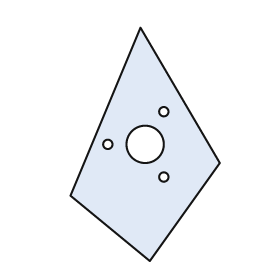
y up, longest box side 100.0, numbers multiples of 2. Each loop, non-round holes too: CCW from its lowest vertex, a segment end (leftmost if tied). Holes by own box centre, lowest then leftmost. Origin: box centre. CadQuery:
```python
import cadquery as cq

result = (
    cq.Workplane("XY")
    .moveTo(2.0, -50.0)
    .lineTo(32.0, -8.0)
    .lineTo(-2.0, 50.0)
    .lineTo(-32.0, -22.0)
    .close()
    .moveTo(8.0, -14.0)
    .circle(2.0)
    .moveTo(-16.0, 0.0)
    .circle(2.0)
    .moveTo(0.0, 0.0)
    .circle(8.0)
    .moveTo(8.0, 14.0)
    .circle(2.0)
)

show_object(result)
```